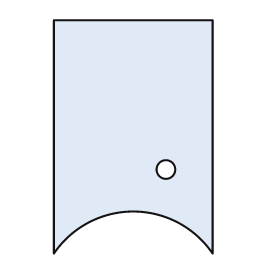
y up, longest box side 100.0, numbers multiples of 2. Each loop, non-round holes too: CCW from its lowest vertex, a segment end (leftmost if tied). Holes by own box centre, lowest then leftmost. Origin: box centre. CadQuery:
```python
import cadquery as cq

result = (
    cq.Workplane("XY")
    .moveTo(-34.0, -50.0)
    .threePointArc((0.0, -32.0), (34.0, -50.0))
    .lineTo(34.0, 50.0)
    .lineTo(-34.0, 50.0)
    .close()
    .moveTo(14.0, -14.0)
    .circle(4.0)
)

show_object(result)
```